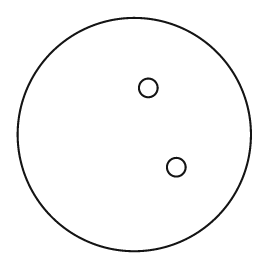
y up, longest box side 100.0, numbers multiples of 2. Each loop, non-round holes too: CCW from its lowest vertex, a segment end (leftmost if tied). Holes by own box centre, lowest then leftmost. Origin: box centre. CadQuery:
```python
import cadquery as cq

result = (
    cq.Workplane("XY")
    .moveTo(0.0, 0.0)
    .circle(50.0)
    .moveTo(18.0, -14.0)
    .circle(4.0)
    .moveTo(6.0, 20.0)
    .circle(4.0)
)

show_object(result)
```